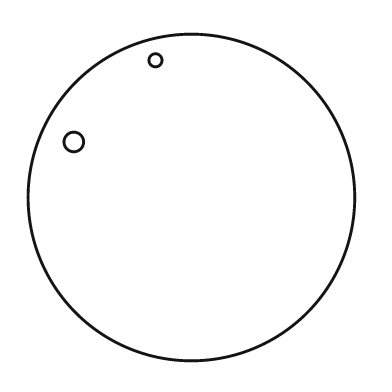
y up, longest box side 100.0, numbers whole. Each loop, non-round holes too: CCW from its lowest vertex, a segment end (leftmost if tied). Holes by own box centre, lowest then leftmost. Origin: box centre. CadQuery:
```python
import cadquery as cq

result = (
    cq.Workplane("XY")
    .moveTo(0.0, 0.0)
    .circle(50.0)
    .moveTo(-36.0, 17.0)
    .circle(3.0)
    .moveTo(-11.0, 42.0)
    .circle(2.0)
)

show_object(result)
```